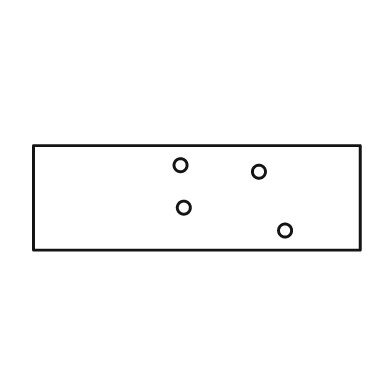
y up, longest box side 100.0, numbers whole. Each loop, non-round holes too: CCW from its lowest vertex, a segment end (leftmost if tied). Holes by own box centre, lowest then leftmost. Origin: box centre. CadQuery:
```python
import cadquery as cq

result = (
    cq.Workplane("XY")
    .moveTo(-50.0, -16.0)
    .lineTo(50.0, -16.0)
    .lineTo(50.0, 16.0)
    .lineTo(-50.0, 16.0)
    .close()
    .moveTo(27.0, -10.0)
    .circle(2.0)
    .moveTo(-4.0, -3.0)
    .circle(2.0)
    .moveTo(19.0, 8.0)
    .circle(2.0)
    .moveTo(-5.0, 10.0)
    .circle(2.0)
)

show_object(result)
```